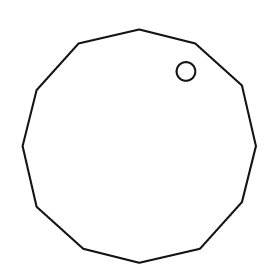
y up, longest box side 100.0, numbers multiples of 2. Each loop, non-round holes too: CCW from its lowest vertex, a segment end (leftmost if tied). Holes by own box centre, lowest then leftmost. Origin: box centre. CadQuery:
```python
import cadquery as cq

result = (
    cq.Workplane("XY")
    .moveTo(0.0, -50.0)
    .lineTo(26.0, -44.0)
    .lineTo(44.0, -24.0)
    .lineTo(50.0, 0.0)
    .lineTo(44.0, 26.0)
    .lineTo(24.0, 44.0)
    .lineTo(0.0, 50.0)
    .lineTo(-26.0, 44.0)
    .lineTo(-44.0, 24.0)
    .lineTo(-50.0, 0.0)
    .lineTo(-44.0, -26.0)
    .lineTo(-24.0, -44.0)
    .close()
    .moveTo(20.0, 32.0)
    .circle(4.0)
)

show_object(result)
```